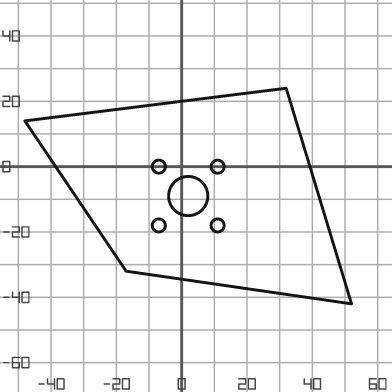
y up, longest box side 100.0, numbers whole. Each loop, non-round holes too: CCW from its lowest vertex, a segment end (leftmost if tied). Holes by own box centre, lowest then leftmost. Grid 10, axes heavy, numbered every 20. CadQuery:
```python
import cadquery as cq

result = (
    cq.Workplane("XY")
    .moveTo(52.0, -42.0)
    .lineTo(32.0, 24.0)
    .lineTo(-48.0, 14.0)
    .lineTo(-17.0, -32.0)
    .close()
    .moveTo(-7.0, -18.0)
    .circle(2.0)
    .moveTo(11.0, -18.0)
    .circle(2.0)
    .moveTo(2.0, -9.0)
    .circle(6.0)
    .moveTo(-7.0, 0.0)
    .circle(2.0)
    .moveTo(11.0, 0.0)
    .circle(2.0)
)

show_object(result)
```